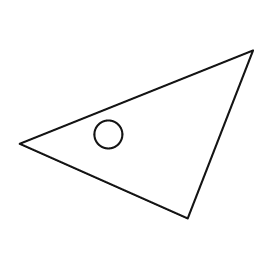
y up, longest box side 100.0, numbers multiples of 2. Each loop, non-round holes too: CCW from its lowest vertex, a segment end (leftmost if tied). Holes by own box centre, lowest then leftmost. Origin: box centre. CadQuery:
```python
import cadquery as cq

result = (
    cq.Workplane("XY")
    .moveTo(22.0, -36.0)
    .lineTo(50.0, 36.0)
    .lineTo(-50.0, -4.0)
    .close()
    .moveTo(-12.0, 0.0)
    .circle(6.0)
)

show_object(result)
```